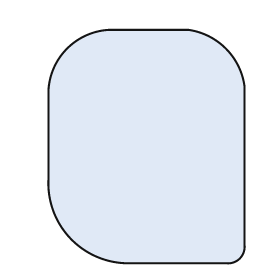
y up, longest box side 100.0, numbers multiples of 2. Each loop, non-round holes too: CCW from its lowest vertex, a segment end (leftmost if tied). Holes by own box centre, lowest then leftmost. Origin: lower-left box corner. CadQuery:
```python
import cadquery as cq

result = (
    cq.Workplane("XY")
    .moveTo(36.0, 0.0)
    .lineTo(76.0, 0.0)
    .threePointArc((82.0, 2.0), (84.0, 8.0))
    .lineTo(84.0, 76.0)
    .threePointArc((76.0, 92.0), (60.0, 100.0))
    .lineTo(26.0, 100.0)
    .threePointArc((8.0, 92.0), (0.0, 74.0))
    .lineTo(0.0, 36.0)
    .threePointArc((10.0, 10.0), (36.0, 0.0))
    .close()
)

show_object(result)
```